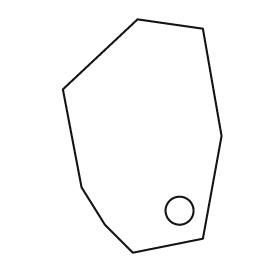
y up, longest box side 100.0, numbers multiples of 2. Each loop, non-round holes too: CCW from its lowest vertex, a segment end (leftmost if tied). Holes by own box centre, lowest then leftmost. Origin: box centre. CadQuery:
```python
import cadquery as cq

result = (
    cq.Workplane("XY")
    .moveTo(-4.0, -50.0)
    .lineTo(26.0, -44.0)
    .lineTo(34.0, 0.0)
    .lineTo(26.0, 46.0)
    .lineTo(-2.0, 50.0)
    .lineTo(-34.0, 20.0)
    .lineTo(-26.0, -22.0)
    .lineTo(-16.0, -38.0)
    .close()
    .moveTo(16.0, -32.0)
    .circle(6.0)
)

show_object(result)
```